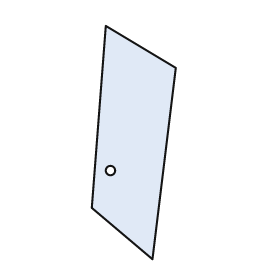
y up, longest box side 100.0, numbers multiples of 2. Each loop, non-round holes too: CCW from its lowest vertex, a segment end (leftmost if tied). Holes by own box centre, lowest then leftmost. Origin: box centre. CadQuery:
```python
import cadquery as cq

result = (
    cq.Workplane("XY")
    .moveTo(8.0, -50.0)
    .lineTo(18.0, 32.0)
    .lineTo(-12.0, 50.0)
    .lineTo(-18.0, -28.0)
    .close()
    .moveTo(-10.0, -12.0)
    .circle(2.0)
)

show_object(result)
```